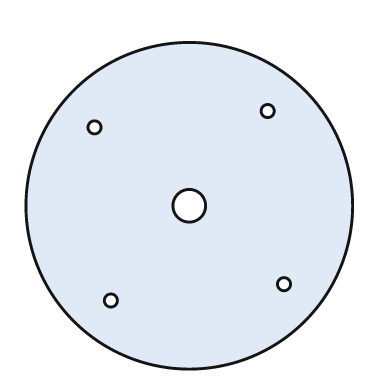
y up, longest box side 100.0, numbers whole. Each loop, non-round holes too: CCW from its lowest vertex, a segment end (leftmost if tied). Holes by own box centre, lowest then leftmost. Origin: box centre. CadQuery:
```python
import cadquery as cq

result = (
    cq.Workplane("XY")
    .moveTo(0.0, 0.0)
    .circle(50.0)
    .moveTo(-24.0, -29.0)
    .circle(2.0)
    .moveTo(29.0, -24.0)
    .circle(2.0)
    .moveTo(0.0, 0.0)
    .circle(5.0)
    .moveTo(-29.0, 24.0)
    .circle(2.0)
    .moveTo(24.0, 29.0)
    .circle(2.0)
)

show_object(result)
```